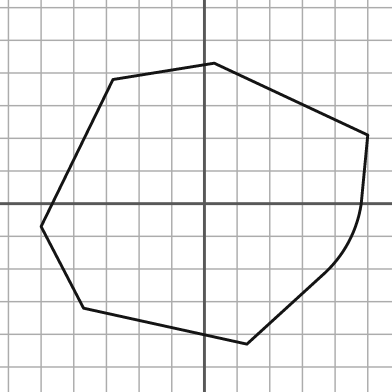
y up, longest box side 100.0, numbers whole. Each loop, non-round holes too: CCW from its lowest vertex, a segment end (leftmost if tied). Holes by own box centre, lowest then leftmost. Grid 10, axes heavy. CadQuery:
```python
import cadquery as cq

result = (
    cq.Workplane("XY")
    .moveTo(13.0, -43.0)
    .lineTo(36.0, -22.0)
    .threePointArc((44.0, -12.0), (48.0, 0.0))
    .lineTo(50.0, 21.0)
    .lineTo(3.0, 43.0)
    .lineTo(-28.0, 38.0)
    .lineTo(-50.0, -7.0)
    .lineTo(-37.0, -32.0)
    .close()
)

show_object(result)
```